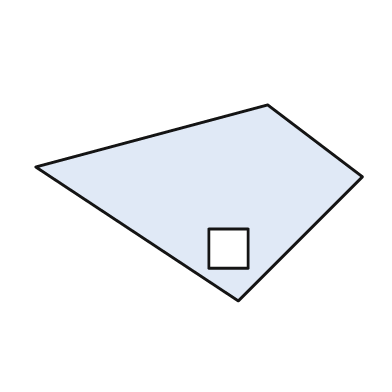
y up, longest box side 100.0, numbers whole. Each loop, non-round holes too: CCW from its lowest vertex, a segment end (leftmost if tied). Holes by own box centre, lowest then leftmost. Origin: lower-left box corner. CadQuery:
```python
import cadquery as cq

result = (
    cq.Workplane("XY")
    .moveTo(62.0, 0.0)
    .lineTo(100.0, 38.0)
    .lineTo(71.0, 60.0)
    .lineTo(0.0, 41.0)
    .close()
    .moveTo(53.0, 10.0)
    .lineTo(65.0, 10.0)
    .lineTo(65.0, 22.0)
    .lineTo(53.0, 22.0)
    .close()
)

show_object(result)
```